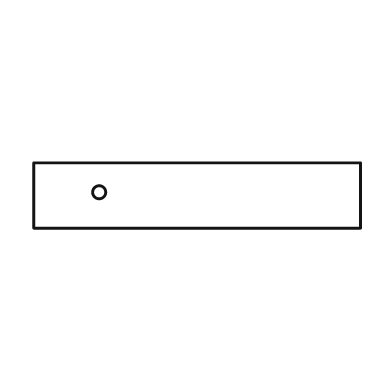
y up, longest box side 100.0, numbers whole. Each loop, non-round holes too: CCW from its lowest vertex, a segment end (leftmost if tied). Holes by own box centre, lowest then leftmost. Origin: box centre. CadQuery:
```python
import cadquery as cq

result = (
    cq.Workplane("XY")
    .moveTo(-50.0, -10.0)
    .lineTo(50.0, -10.0)
    .lineTo(50.0, 10.0)
    .lineTo(-50.0, 10.0)
    .close()
    .moveTo(-30.0, 1.0)
    .circle(2.0)
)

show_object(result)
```